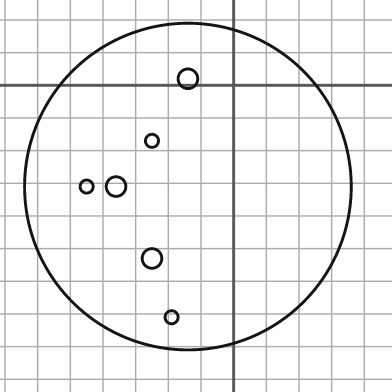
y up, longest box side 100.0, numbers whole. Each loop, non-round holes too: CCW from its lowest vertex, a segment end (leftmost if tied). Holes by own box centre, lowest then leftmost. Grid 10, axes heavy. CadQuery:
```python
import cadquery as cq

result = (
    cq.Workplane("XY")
    .moveTo(-14.0, -31.0)
    .circle(50.0)
    .moveTo(-19.0, -71.0)
    .circle(2.0)
    .moveTo(-25.0, -53.0)
    .circle(3.0)
    .moveTo(-45.0, -31.0)
    .circle(2.0)
    .moveTo(-36.0, -31.0)
    .circle(3.0)
    .moveTo(-25.0, -17.0)
    .circle(2.0)
    .moveTo(-14.0, 2.0)
    .circle(3.0)
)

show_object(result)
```